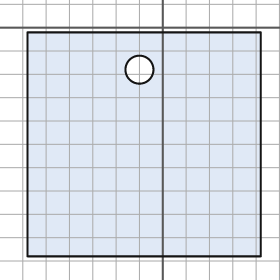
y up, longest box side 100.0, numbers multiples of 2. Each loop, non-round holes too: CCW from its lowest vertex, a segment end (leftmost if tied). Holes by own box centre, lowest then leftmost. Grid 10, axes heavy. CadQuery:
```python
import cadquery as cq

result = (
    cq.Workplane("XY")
    .moveTo(-58.0, -98.0)
    .lineTo(42.0, -98.0)
    .lineTo(42.0, -2.0)
    .lineTo(-58.0, -2.0)
    .close()
    .moveTo(-10.0, -18.0)
    .circle(6.0)
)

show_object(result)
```